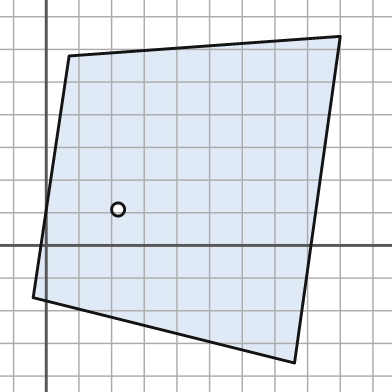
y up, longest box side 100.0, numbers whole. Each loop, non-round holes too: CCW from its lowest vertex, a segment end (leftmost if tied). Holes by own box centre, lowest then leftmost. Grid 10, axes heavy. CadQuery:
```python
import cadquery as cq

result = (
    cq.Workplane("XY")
    .moveTo(76.0, -36.0)
    .lineTo(90.0, 64.0)
    .lineTo(7.0, 58.0)
    .lineTo(-4.0, -16.0)
    .close()
    .moveTo(22.0, 11.0)
    .circle(2.0)
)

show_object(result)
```